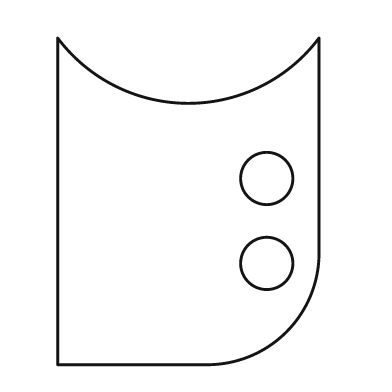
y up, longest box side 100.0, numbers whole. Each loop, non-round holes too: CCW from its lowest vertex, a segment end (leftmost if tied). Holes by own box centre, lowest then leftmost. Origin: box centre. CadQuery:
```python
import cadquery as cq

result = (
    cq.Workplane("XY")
    .moveTo(-40.0, -50.0)
    .lineTo(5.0, -50.0)
    .threePointArc((30.0, -40.0), (40.0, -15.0))
    .lineTo(40.0, 50.0)
    .threePointArc((0.0, 30.0), (-40.0, 50.0))
    .close()
    .moveTo(24.0, -19.0)
    .circle(8.0)
    .moveTo(24.0, 7.0)
    .circle(8.0)
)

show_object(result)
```